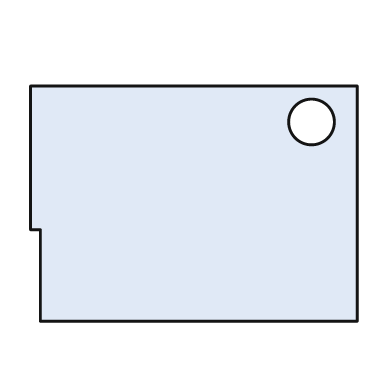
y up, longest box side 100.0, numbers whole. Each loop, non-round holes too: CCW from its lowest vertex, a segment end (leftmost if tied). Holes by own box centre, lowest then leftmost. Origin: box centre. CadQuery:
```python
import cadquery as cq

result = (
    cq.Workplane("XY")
    .moveTo(-47.0, -36.0)
    .lineTo(50.0, -36.0)
    .lineTo(50.0, 36.0)
    .lineTo(-50.0, 36.0)
    .lineTo(-50.0, -8.0)
    .lineTo(-47.0, -8.0)
    .close()
    .moveTo(36.0, 25.0)
    .circle(7.0)
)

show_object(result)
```